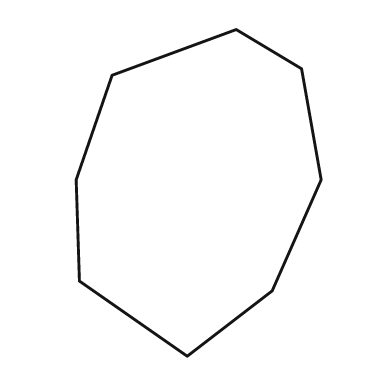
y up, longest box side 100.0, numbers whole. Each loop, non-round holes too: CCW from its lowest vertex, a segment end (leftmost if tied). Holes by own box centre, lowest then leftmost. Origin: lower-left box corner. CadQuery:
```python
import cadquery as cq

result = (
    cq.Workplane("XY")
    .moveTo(34.0, 0.0)
    .lineTo(60.0, 20.0)
    .lineTo(75.0, 54.0)
    .lineTo(69.0, 88.0)
    .lineTo(49.0, 100.0)
    .lineTo(11.0, 86.0)
    .lineTo(0.0, 54.0)
    .lineTo(1.0, 23.0)
    .close()
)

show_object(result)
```